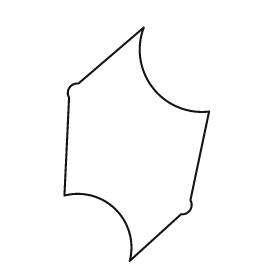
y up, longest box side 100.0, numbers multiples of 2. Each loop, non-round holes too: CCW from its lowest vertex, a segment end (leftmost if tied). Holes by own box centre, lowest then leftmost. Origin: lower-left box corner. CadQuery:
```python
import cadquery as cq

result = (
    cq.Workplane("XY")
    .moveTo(28.0, 0.0)
    .lineTo(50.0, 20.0)
    .threePointArc((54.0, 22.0), (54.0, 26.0))
    .lineTo(62.0, 64.0)
    .threePointArc((38.0, 74.0), (34.0, 100.0))
    .lineTo(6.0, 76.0)
    .threePointArc((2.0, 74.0), (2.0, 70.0))
    .lineTo(0.0, 28.0)
    .threePointArc((22.0, 22.0), (28.0, 0.0))
    .close()
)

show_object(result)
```